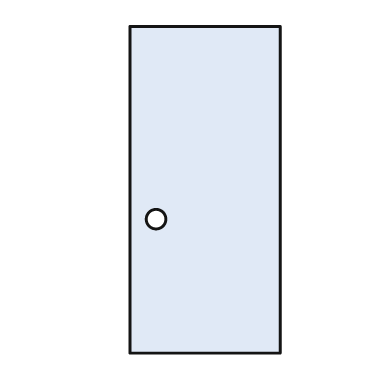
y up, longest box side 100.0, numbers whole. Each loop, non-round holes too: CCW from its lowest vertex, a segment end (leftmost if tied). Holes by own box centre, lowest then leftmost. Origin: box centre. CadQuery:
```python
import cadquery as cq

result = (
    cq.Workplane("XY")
    .moveTo(-23.0, -50.0)
    .lineTo(23.0, -50.0)
    .lineTo(23.0, 50.0)
    .lineTo(-23.0, 50.0)
    .close()
    .moveTo(-15.0, -9.0)
    .circle(3.0)
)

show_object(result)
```